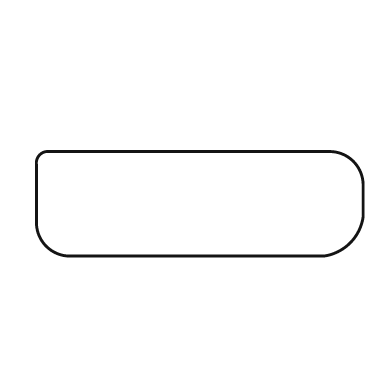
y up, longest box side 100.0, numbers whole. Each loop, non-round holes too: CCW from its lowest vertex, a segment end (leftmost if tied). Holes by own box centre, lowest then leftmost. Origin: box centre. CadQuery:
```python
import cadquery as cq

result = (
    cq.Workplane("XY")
    .moveTo(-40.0, -16.0)
    .lineTo(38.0, -16.0)
    .threePointArc((46.0, -12.0), (50.0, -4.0))
    .lineTo(50.0, 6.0)
    .threePointArc((47.0, 13.0), (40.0, 16.0))
    .lineTo(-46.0, 16.0)
    .threePointArc((-49.0, 15.0), (-50.0, 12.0))
    .lineTo(-50.0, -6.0)
    .threePointArc((-47.0, -13.0), (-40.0, -16.0))
    .close()
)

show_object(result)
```